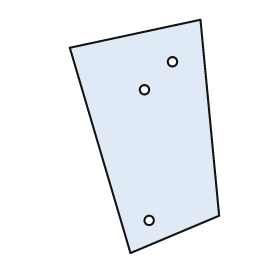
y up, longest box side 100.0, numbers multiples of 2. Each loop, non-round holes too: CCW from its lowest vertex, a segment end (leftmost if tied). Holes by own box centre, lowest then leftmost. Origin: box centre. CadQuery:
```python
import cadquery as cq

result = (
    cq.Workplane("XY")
    .moveTo(-6.0, -50.0)
    .lineTo(32.0, -34.0)
    .lineTo(24.0, 50.0)
    .lineTo(-32.0, 38.0)
    .close()
    .moveTo(2.0, -36.0)
    .circle(2.0)
    .moveTo(0.0, 20.0)
    .circle(2.0)
    .moveTo(12.0, 32.0)
    .circle(2.0)
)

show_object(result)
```